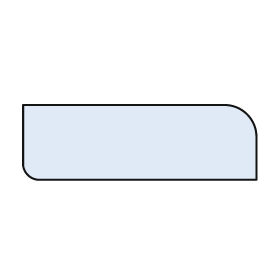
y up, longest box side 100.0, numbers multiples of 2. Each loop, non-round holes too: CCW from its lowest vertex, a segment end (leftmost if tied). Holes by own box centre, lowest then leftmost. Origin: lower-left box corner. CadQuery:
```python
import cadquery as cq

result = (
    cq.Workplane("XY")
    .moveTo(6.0, 0.0)
    .lineTo(100.0, 0.0)
    .lineTo(100.0, 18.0)
    .threePointArc((96.0, 28.0), (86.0, 32.0))
    .lineTo(0.0, 32.0)
    .lineTo(0.0, 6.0)
    .threePointArc((2.0, 2.0), (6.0, 0.0))
    .close()
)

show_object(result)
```